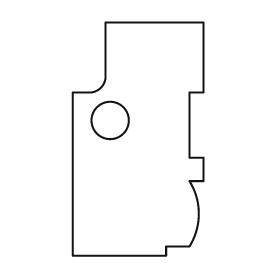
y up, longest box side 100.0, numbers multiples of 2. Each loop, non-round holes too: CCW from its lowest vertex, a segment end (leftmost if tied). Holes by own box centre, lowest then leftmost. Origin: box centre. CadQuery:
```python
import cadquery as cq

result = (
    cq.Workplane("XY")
    .moveTo(-28.0, -50.0)
    .lineTo(12.0, -50.0)
    .lineTo(12.0, -46.0)
    .lineTo(22.0, -46.0)
    .threePointArc((26.0, -32.0), (22.0, -18.0))
    .lineTo(28.0, -18.0)
    .lineTo(28.0, -8.0)
    .lineTo(22.0, -8.0)
    .lineTo(22.0, 20.0)
    .lineTo(28.0, 20.0)
    .lineTo(28.0, 50.0)
    .lineTo(-14.0, 50.0)
    .lineTo(-14.0, 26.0)
    .threePointArc((-16.0, 22.0), (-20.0, 20.0))
    .lineTo(-28.0, 20.0)
    .close()
    .moveTo(-12.0, 8.0)
    .circle(8.0)
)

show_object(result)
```